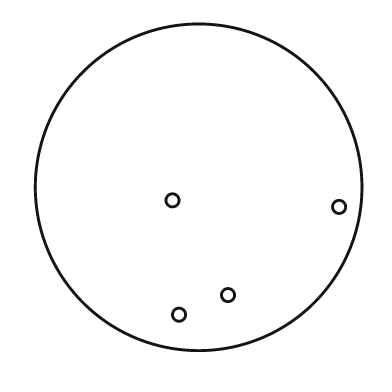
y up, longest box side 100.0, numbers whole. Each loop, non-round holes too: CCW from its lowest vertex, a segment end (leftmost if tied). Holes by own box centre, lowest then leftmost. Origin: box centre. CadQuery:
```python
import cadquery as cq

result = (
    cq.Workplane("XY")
    .moveTo(0.0, 0.0)
    .circle(50.0)
    .moveTo(-6.0, -39.0)
    .circle(2.0)
    .moveTo(9.0, -33.0)
    .circle(2.0)
    .moveTo(43.0, -6.0)
    .circle(2.0)
    .moveTo(-8.0, -4.0)
    .circle(2.0)
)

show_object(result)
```